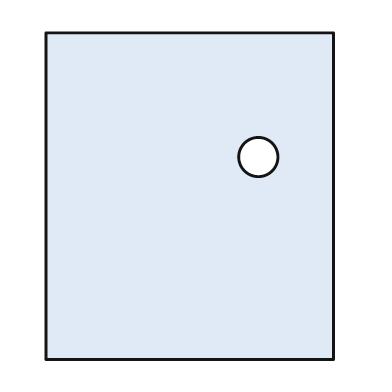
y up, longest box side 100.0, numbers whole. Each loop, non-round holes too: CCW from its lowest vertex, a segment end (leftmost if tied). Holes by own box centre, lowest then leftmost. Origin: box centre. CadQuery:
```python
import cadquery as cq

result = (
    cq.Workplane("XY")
    .moveTo(-44.0, -50.0)
    .lineTo(44.0, -50.0)
    .lineTo(44.0, 50.0)
    .lineTo(-44.0, 50.0)
    .close()
    .moveTo(21.0, 12.0)
    .circle(6.0)
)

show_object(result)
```